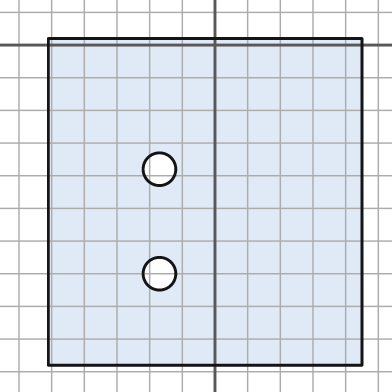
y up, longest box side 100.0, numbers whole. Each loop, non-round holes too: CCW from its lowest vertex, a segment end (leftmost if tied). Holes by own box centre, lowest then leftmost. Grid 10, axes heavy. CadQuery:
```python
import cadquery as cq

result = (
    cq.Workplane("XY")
    .moveTo(-51.0, -98.0)
    .lineTo(45.0, -98.0)
    .lineTo(45.0, 2.0)
    .lineTo(-51.0, 2.0)
    .close()
    .moveTo(-17.0, -70.0)
    .circle(5.0)
    .moveTo(-17.0, -38.0)
    .circle(5.0)
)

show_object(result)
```